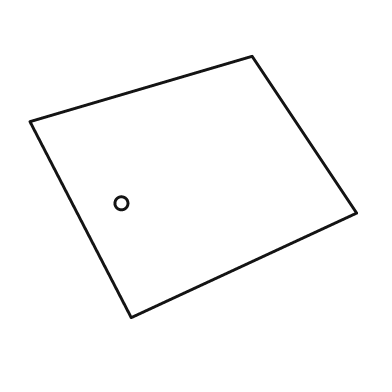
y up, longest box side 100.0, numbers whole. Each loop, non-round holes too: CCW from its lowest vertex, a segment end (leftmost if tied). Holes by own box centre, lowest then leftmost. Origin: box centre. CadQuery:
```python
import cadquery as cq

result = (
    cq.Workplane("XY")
    .moveTo(-19.0, -40.0)
    .lineTo(50.0, -8.0)
    .lineTo(18.0, 40.0)
    .lineTo(-50.0, 20.0)
    .close()
    .moveTo(-22.0, -5.0)
    .circle(2.0)
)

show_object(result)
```